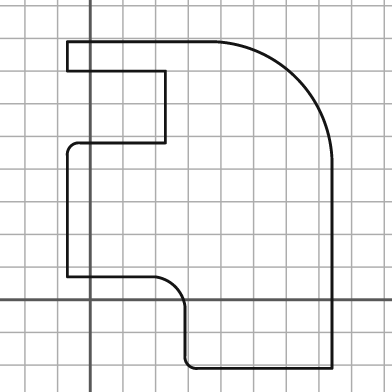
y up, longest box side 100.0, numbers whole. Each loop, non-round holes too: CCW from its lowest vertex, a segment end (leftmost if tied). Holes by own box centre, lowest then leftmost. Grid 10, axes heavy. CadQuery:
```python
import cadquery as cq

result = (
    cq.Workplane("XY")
    .moveTo(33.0, -21.0)
    .lineTo(74.0, -21.0)
    .lineTo(74.0, 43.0)
    .threePointArc((63.0, 68.0), (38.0, 79.0))
    .lineTo(-7.0, 79.0)
    .lineTo(-7.0, 70.0)
    .lineTo(23.0, 70.0)
    .lineTo(23.0, 48.0)
    .lineTo(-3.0, 48.0)
    .threePointArc((-6.0, 47.0), (-7.0, 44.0))
    .lineTo(-7.0, 7.0)
    .lineTo(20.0, 7.0)
    .threePointArc((26.0, 4.0), (29.0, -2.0))
    .lineTo(29.0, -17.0)
    .threePointArc((30.0, -20.0), (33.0, -21.0))
    .close()
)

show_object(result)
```